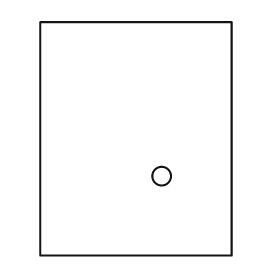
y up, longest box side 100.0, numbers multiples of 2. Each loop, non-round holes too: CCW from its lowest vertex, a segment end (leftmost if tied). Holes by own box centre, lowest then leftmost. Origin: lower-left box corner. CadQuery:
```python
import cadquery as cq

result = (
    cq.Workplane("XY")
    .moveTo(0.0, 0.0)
    .lineTo(82.0, 0.0)
    .lineTo(82.0, 100.0)
    .lineTo(0.0, 100.0)
    .close()
    .moveTo(52.0, 34.0)
    .circle(4.0)
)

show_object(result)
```